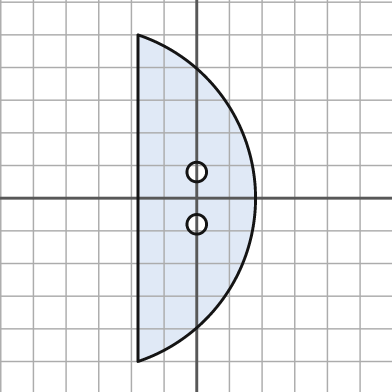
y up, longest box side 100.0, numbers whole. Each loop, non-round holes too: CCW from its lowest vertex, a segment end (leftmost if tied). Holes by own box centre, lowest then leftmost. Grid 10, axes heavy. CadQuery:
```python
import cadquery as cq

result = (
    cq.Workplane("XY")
    .moveTo(-18.0, -50.0)
    .threePointArc((18.0, 0.0), (-18.0, 50.0))
    .close()
    .moveTo(0.0, -8.0)
    .circle(3.0)
    .moveTo(0.0, 8.0)
    .circle(3.0)
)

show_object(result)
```